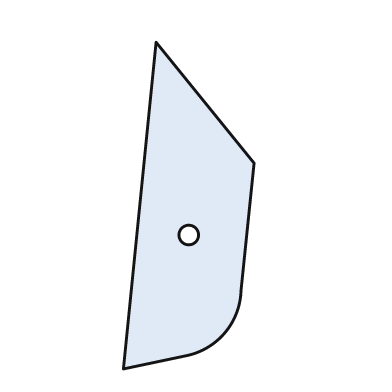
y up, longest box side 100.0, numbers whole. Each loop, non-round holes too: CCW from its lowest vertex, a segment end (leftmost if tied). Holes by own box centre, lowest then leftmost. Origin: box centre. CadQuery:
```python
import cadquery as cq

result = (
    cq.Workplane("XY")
    .moveTo(-20.0, -50.0)
    .lineTo(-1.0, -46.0)
    .threePointArc((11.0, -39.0), (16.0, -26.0))
    .lineTo(20.0, 13.0)
    .lineTo(-10.0, 50.0)
    .close()
    .moveTo(0.0, -9.0)
    .circle(3.0)
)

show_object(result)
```